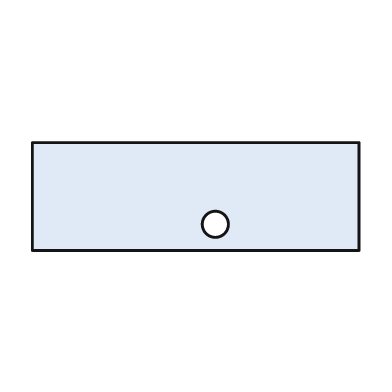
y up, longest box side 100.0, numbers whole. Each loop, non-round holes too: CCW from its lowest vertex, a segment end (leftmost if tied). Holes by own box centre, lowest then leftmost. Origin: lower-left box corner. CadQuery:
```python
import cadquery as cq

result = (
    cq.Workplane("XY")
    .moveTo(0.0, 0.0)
    .lineTo(100.0, 0.0)
    .lineTo(100.0, 33.0)
    .lineTo(0.0, 33.0)
    .close()
    .moveTo(56.0, 8.0)
    .circle(4.0)
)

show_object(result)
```